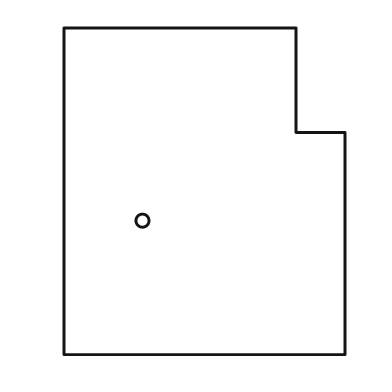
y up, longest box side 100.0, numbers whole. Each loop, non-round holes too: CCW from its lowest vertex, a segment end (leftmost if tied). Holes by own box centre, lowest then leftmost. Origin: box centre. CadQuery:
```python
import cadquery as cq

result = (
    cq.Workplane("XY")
    .moveTo(-43.0, -50.0)
    .lineTo(43.0, -50.0)
    .lineTo(43.0, 18.0)
    .lineTo(28.0, 18.0)
    .lineTo(28.0, 50.0)
    .lineTo(-43.0, 50.0)
    .close()
    .moveTo(-19.0, -9.0)
    .circle(2.0)
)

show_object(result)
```